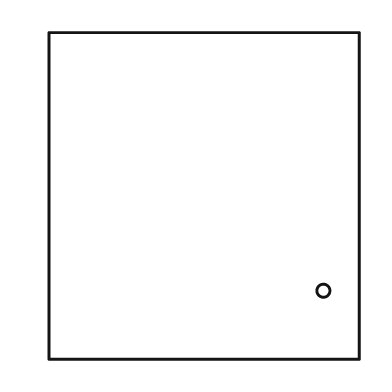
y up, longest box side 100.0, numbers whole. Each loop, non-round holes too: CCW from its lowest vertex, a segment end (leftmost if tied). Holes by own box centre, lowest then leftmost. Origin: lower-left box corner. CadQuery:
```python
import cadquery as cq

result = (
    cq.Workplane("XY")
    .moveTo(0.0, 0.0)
    .lineTo(95.0, 0.0)
    .lineTo(95.0, 100.0)
    .lineTo(0.0, 100.0)
    .close()
    .moveTo(84.0, 21.0)
    .circle(2.0)
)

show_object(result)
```